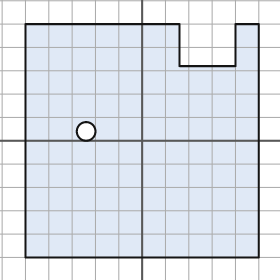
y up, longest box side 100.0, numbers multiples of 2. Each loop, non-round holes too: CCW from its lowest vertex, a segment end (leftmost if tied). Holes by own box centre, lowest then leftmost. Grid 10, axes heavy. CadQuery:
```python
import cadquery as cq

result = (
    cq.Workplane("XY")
    .moveTo(-50.0, -50.0)
    .lineTo(50.0, -50.0)
    .lineTo(50.0, 50.0)
    .lineTo(40.0, 50.0)
    .lineTo(40.0, 32.0)
    .lineTo(16.0, 32.0)
    .lineTo(16.0, 50.0)
    .lineTo(-50.0, 50.0)
    .close()
    .moveTo(-24.0, 4.0)
    .circle(4.0)
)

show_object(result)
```